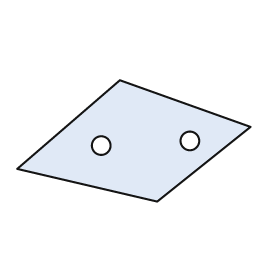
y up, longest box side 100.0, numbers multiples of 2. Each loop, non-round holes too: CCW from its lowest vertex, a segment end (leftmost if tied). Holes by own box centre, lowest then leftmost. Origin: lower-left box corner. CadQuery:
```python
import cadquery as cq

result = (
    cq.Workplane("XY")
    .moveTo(60.0, 0.0)
    .lineTo(100.0, 32.0)
    .lineTo(44.0, 52.0)
    .lineTo(0.0, 14.0)
    .close()
    .moveTo(36.0, 24.0)
    .circle(4.0)
    .moveTo(74.0, 26.0)
    .circle(4.0)
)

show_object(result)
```